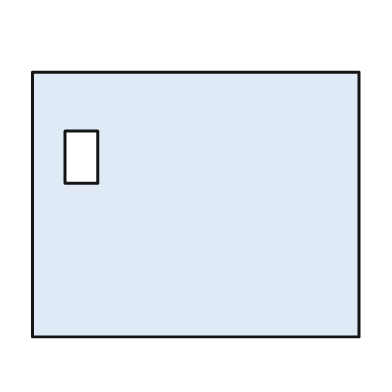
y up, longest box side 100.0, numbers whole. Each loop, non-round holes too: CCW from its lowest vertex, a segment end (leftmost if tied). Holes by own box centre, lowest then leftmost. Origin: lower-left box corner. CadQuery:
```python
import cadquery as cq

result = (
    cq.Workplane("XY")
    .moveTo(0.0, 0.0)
    .lineTo(100.0, 0.0)
    .lineTo(100.0, 81.0)
    .lineTo(0.0, 81.0)
    .close()
    .moveTo(10.0, 47.0)
    .lineTo(20.0, 47.0)
    .lineTo(20.0, 63.0)
    .lineTo(10.0, 63.0)
    .close()
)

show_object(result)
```